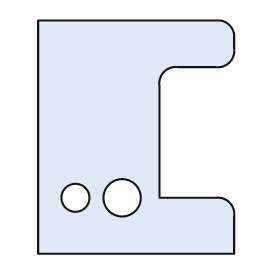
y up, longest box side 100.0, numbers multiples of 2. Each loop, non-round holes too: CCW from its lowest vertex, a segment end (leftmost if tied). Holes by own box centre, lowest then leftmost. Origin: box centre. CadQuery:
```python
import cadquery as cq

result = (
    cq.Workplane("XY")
    .moveTo(-42.0, -50.0)
    .lineTo(42.0, -50.0)
    .lineTo(42.0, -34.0)
    .threePointArc((40.0, -28.0), (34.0, -26.0))
    .lineTo(10.0, -26.0)
    .lineTo(10.0, 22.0)
    .threePointArc((12.0, 28.0), (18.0, 30.0))
    .lineTo(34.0, 30.0)
    .threePointArc((40.0, 32.0), (42.0, 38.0))
    .lineTo(42.0, 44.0)
    .threePointArc((40.0, 48.0), (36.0, 50.0))
    .lineTo(-42.0, 50.0)
    .close()
    .moveTo(-26.0, -26.0)
    .circle(6.0)
    .moveTo(-6.0, -26.0)
    .circle(8.0)
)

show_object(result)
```